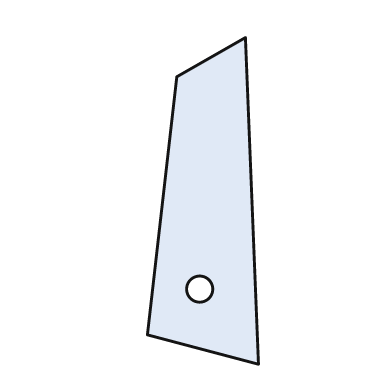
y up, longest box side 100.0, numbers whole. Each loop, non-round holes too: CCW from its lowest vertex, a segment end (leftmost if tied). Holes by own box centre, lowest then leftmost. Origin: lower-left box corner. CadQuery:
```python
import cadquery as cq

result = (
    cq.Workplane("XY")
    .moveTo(34.0, 0.0)
    .lineTo(30.0, 100.0)
    .lineTo(9.0, 88.0)
    .lineTo(0.0, 9.0)
    .close()
    .moveTo(16.0, 23.0)
    .circle(4.0)
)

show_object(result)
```